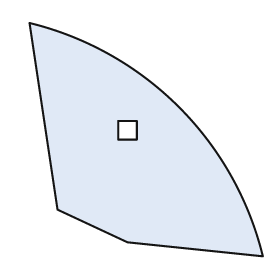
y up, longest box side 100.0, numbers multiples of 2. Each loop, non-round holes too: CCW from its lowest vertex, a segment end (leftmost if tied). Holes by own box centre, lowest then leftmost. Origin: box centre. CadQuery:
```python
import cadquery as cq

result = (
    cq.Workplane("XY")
    .moveTo(50.0, -50.0)
    .threePointArc((14.0, 14.0), (-50.0, 50.0))
    .lineTo(-38.0, -30.0)
    .lineTo(-8.0, -44.0)
    .close()
    .moveTo(-12.0, 0.0)
    .lineTo(-4.0, 0.0)
    .lineTo(-4.0, 8.0)
    .lineTo(-12.0, 8.0)
    .close()
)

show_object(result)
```